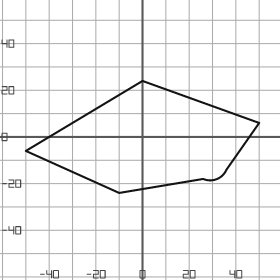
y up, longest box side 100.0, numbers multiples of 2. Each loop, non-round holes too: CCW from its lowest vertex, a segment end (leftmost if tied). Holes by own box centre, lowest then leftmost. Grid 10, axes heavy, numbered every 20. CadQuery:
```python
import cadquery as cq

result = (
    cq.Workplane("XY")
    .moveTo(-10.0, -24.0)
    .lineTo(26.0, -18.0)
    .threePointArc((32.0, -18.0), (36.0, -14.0))
    .lineTo(50.0, 6.0)
    .lineTo(0.0, 24.0)
    .lineTo(-50.0, -6.0)
    .close()
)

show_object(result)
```